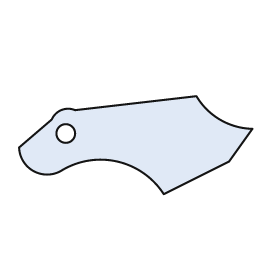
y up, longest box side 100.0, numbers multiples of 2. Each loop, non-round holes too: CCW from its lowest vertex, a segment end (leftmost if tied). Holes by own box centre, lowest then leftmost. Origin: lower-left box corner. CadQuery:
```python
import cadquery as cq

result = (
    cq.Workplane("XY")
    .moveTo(62.0, 0.0)
    .lineTo(90.0, 14.0)
    .lineTo(100.0, 28.0)
    .threePointArc((86.0, 32.0), (76.0, 42.0))
    .lineTo(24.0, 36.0)
    .threePointArc((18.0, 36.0), (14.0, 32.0))
    .lineTo(0.0, 20.0)
    .threePointArc((6.0, 10.0), (18.0, 10.0))
    .threePointArc((42.0, 14.0), (62.0, 0.0))
    .close()
    .moveTo(20.0, 26.0)
    .circle(4.0)
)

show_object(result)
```